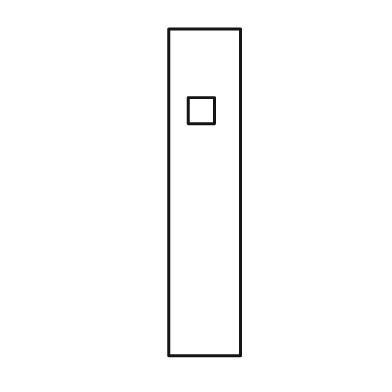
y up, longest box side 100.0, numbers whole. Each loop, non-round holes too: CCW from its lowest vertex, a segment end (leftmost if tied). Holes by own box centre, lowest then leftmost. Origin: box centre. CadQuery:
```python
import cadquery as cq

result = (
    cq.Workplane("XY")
    .moveTo(-11.0, -50.0)
    .lineTo(11.0, -50.0)
    .lineTo(11.0, 50.0)
    .lineTo(-11.0, 50.0)
    .close()
    .moveTo(-5.0, 21.0)
    .lineTo(3.0, 21.0)
    .lineTo(3.0, 29.0)
    .lineTo(-5.0, 29.0)
    .close()
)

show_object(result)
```